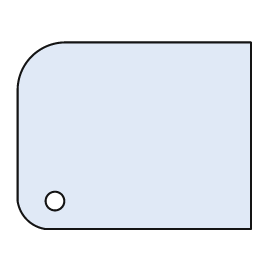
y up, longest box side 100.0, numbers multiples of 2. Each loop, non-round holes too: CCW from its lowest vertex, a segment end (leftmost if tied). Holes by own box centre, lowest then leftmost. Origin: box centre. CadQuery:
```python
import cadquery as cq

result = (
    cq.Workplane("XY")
    .moveTo(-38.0, -40.0)
    .lineTo(50.0, -40.0)
    .lineTo(50.0, 40.0)
    .lineTo(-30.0, 40.0)
    .threePointArc((-44.0, 34.0), (-50.0, 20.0))
    .lineTo(-50.0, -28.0)
    .threePointArc((-46.0, -36.0), (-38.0, -40.0))
    .close()
    .moveTo(-34.0, -28.0)
    .circle(4.0)
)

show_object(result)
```